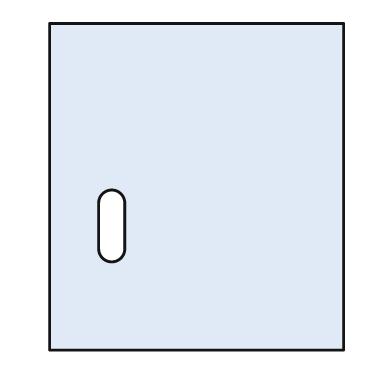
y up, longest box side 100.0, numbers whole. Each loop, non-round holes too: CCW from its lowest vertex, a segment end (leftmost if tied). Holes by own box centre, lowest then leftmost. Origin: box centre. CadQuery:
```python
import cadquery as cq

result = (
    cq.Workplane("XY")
    .moveTo(-45.0, -50.0)
    .lineTo(45.0, -50.0)
    .lineTo(45.0, 50.0)
    .lineTo(-45.0, 50.0)
    .close()
    .moveTo(-30.0, -19.0)
    .threePointArc((-26.0, -23.0), (-22.0, -19.0))
    .lineTo(-22.0, -5.0)
    .threePointArc((-26.0, -1.0), (-30.0, -5.0))
    .close()
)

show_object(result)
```